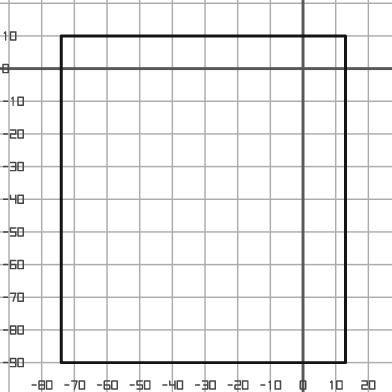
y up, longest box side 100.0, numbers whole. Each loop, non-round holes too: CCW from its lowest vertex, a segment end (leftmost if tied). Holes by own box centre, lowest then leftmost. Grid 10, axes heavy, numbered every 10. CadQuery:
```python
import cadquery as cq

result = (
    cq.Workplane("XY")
    .moveTo(-74.0, -90.0)
    .lineTo(13.0, -90.0)
    .lineTo(13.0, 10.0)
    .lineTo(-74.0, 10.0)
    .close()
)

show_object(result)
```